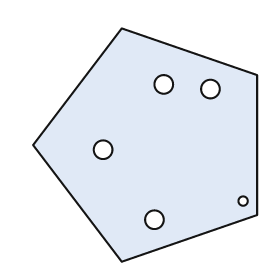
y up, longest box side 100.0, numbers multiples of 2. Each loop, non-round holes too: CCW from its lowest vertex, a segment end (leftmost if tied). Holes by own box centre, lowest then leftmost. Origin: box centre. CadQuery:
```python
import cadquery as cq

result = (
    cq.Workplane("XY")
    .moveTo(-10.0, -50.0)
    .lineTo(48.0, -30.0)
    .lineTo(48.0, 30.0)
    .lineTo(-10.0, 50.0)
    .lineTo(-48.0, 0.0)
    .close()
    .moveTo(4.0, -32.0)
    .circle(4.0)
    .moveTo(42.0, -24.0)
    .circle(2.0)
    .moveTo(-18.0, -2.0)
    .circle(4.0)
    .moveTo(28.0, 24.0)
    .circle(4.0)
    .moveTo(8.0, 26.0)
    .circle(4.0)
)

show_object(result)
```